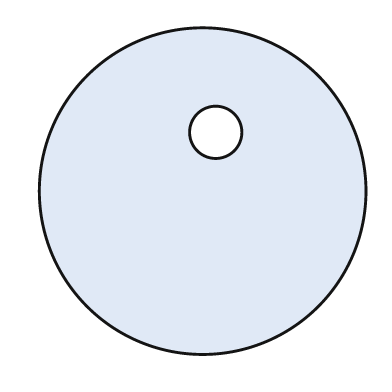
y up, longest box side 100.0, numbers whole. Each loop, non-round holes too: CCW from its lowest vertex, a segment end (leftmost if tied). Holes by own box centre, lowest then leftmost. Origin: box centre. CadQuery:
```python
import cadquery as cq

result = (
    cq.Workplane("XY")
    .moveTo(0.0, 0.0)
    .circle(50.0)
    .moveTo(4.0, 18.0)
    .circle(8.0)
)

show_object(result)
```